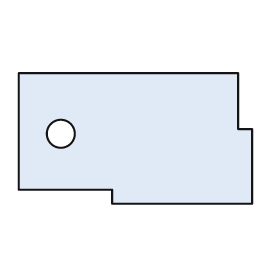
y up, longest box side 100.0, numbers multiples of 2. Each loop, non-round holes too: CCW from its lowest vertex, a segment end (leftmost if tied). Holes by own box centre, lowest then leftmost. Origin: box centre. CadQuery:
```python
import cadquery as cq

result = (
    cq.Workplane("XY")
    .moveTo(-10.0, -28.0)
    .lineTo(50.0, -28.0)
    .lineTo(50.0, 4.0)
    .lineTo(44.0, 4.0)
    .lineTo(44.0, 28.0)
    .lineTo(-50.0, 28.0)
    .lineTo(-50.0, -22.0)
    .lineTo(-10.0, -22.0)
    .close()
    .moveTo(-32.0, 2.0)
    .circle(6.0)
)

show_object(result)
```